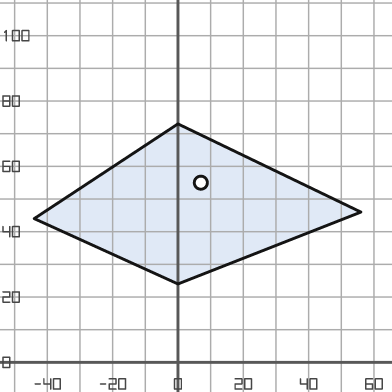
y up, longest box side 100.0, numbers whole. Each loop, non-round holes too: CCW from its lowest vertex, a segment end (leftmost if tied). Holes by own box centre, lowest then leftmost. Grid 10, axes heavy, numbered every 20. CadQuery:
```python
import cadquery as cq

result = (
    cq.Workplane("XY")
    .moveTo(0.0, 24.0)
    .lineTo(56.0, 46.0)
    .lineTo(0.0, 73.0)
    .lineTo(-44.0, 44.0)
    .close()
    .moveTo(7.0, 55.0)
    .circle(2.0)
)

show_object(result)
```